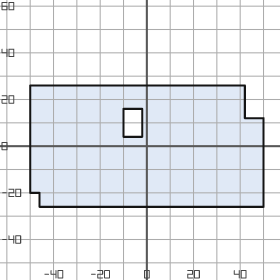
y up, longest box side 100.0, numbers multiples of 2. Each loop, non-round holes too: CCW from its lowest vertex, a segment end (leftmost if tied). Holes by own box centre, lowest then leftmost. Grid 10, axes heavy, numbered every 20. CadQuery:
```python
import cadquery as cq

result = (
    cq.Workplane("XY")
    .moveTo(-46.0, -26.0)
    .lineTo(50.0, -26.0)
    .lineTo(50.0, 12.0)
    .lineTo(42.0, 12.0)
    .lineTo(42.0, 26.0)
    .lineTo(-50.0, 26.0)
    .lineTo(-50.0, -20.0)
    .lineTo(-46.0, -20.0)
    .close()
    .moveTo(-10.0, 4.0)
    .lineTo(-2.0, 4.0)
    .lineTo(-2.0, 16.0)
    .lineTo(-10.0, 16.0)
    .close()
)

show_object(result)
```